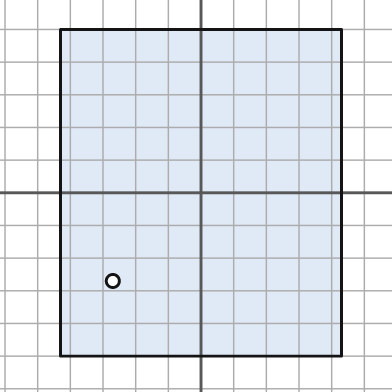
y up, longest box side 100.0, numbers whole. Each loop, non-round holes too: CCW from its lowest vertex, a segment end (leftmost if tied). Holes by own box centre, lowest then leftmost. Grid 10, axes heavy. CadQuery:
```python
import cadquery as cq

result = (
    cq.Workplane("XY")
    .moveTo(-43.0, -50.0)
    .lineTo(43.0, -50.0)
    .lineTo(43.0, 50.0)
    .lineTo(-43.0, 50.0)
    .close()
    .moveTo(-27.0, -27.0)
    .circle(2.0)
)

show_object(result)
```